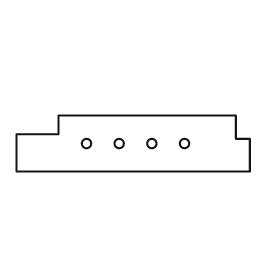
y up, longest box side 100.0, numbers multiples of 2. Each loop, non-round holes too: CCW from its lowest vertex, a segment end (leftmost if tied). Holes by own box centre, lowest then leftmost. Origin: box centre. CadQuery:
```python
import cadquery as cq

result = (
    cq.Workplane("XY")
    .moveTo(-50.0, -12.0)
    .lineTo(50.0, -12.0)
    .lineTo(50.0, 2.0)
    .lineTo(44.0, 2.0)
    .lineTo(44.0, 12.0)
    .lineTo(-32.0, 12.0)
    .lineTo(-32.0, 4.0)
    .lineTo(-50.0, 4.0)
    .close()
    .moveTo(-20.0, 0.0)
    .circle(2.0)
    .moveTo(-6.0, 0.0)
    .circle(2.0)
    .moveTo(8.0, 0.0)
    .circle(2.0)
    .moveTo(22.0, 0.0)
    .circle(2.0)
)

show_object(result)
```